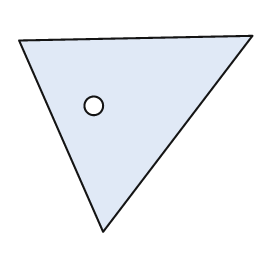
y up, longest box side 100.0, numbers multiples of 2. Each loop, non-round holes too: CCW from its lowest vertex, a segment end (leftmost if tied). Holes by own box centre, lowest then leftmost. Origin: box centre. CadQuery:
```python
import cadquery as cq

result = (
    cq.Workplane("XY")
    .moveTo(-14.0, -42.0)
    .lineTo(50.0, 42.0)
    .lineTo(-50.0, 40.0)
    .close()
    .moveTo(-18.0, 12.0)
    .circle(4.0)
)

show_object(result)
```